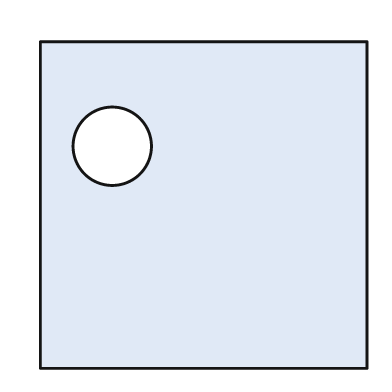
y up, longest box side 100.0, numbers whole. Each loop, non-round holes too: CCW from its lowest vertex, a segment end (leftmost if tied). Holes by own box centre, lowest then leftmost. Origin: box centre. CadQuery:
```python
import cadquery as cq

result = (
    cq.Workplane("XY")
    .moveTo(-50.0, -50.0)
    .lineTo(50.0, -50.0)
    .lineTo(50.0, 50.0)
    .lineTo(-50.0, 50.0)
    .close()
    .moveTo(-28.0, 18.0)
    .circle(12.0)
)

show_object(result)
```